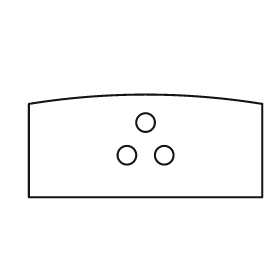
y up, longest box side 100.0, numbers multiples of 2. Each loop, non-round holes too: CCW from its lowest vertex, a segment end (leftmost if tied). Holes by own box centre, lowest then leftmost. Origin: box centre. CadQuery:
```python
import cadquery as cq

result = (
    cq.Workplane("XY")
    .moveTo(-50.0, -22.0)
    .lineTo(50.0, -22.0)
    .lineTo(50.0, 18.0)
    .threePointArc((0.0, 22.0), (-50.0, 18.0))
    .close()
    .moveTo(-8.0, -4.0)
    .circle(4.0)
    .moveTo(8.0, -4.0)
    .circle(4.0)
    .moveTo(0.0, 10.0)
    .circle(4.0)
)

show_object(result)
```